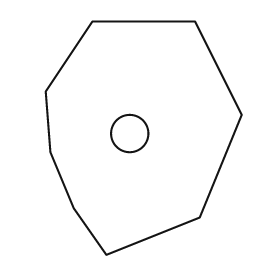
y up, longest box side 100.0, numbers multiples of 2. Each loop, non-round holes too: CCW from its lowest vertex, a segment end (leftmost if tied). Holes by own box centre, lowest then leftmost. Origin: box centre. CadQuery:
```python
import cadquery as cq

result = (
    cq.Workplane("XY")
    .moveTo(-16.0, -50.0)
    .lineTo(24.0, -34.0)
    .lineTo(42.0, 10.0)
    .lineTo(22.0, 50.0)
    .lineTo(-22.0, 50.0)
    .lineTo(-42.0, 20.0)
    .lineTo(-40.0, -6.0)
    .lineTo(-30.0, -30.0)
    .close()
    .moveTo(-6.0, 2.0)
    .circle(8.0)
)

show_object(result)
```